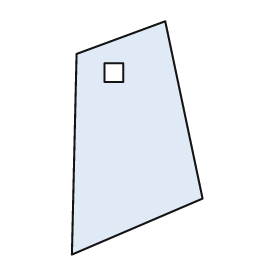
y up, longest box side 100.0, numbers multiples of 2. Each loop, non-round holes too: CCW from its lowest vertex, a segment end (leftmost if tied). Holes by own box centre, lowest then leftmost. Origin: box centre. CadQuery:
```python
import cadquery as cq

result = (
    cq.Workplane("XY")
    .moveTo(-28.0, -50.0)
    .lineTo(28.0, -26.0)
    .lineTo(12.0, 50.0)
    .lineTo(-26.0, 36.0)
    .close()
    .moveTo(-14.0, 24.0)
    .lineTo(-6.0, 24.0)
    .lineTo(-6.0, 32.0)
    .lineTo(-14.0, 32.0)
    .close()
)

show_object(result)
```